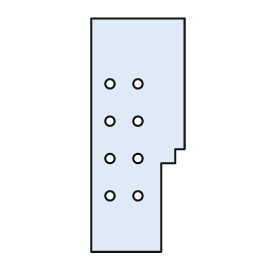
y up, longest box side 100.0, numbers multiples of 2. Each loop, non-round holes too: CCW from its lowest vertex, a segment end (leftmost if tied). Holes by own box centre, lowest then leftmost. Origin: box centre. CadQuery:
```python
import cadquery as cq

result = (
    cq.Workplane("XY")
    .moveTo(-20.0, -50.0)
    .lineTo(10.0, -50.0)
    .lineTo(10.0, -12.0)
    .lineTo(16.0, -12.0)
    .lineTo(16.0, -6.0)
    .lineTo(20.0, -6.0)
    .lineTo(20.0, 50.0)
    .lineTo(-20.0, 50.0)
    .close()
    .moveTo(-12.0, -26.0)
    .circle(2.0)
    .moveTo(0.0, -26.0)
    .circle(2.0)
    .moveTo(-12.0, -10.0)
    .circle(2.0)
    .moveTo(0.0, -10.0)
    .circle(2.0)
    .moveTo(-12.0, 6.0)
    .circle(2.0)
    .moveTo(0.0, 6.0)
    .circle(2.0)
    .moveTo(-12.0, 22.0)
    .circle(2.0)
    .moveTo(0.0, 22.0)
    .circle(2.0)
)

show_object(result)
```